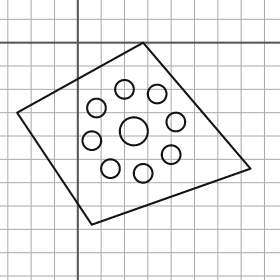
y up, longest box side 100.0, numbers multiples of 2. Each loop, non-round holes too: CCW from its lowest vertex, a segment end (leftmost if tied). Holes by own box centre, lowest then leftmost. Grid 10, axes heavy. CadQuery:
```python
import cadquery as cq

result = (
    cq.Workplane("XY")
    .moveTo(6.0, -78.0)
    .lineTo(74.0, -54.0)
    .lineTo(28.0, 0.0)
    .lineTo(-26.0, -30.0)
    .close()
    .moveTo(28.0, -56.0)
    .circle(4.0)
    .moveTo(14.0, -54.0)
    .circle(4.0)
    .moveTo(40.0, -48.0)
    .circle(4.0)
    .moveTo(6.0, -42.0)
    .circle(4.0)
    .moveTo(24.0, -38.0)
    .circle(6.0)
    .moveTo(42.0, -34.0)
    .circle(4.0)
    .moveTo(8.0, -28.0)
    .circle(4.0)
    .moveTo(34.0, -22.0)
    .circle(4.0)
    .moveTo(20.0, -20.0)
    .circle(4.0)
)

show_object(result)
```